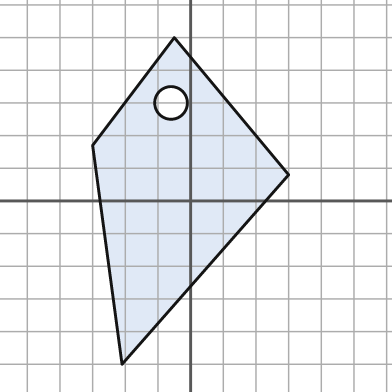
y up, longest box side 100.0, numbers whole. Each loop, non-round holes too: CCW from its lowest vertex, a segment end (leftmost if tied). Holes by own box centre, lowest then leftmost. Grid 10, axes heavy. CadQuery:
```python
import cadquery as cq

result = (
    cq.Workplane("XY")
    .moveTo(-21.0, -50.0)
    .lineTo(30.0, 8.0)
    .lineTo(-5.0, 50.0)
    .lineTo(-30.0, 17.0)
    .close()
    .moveTo(-6.0, 30.0)
    .circle(5.0)
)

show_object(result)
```